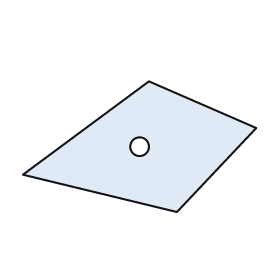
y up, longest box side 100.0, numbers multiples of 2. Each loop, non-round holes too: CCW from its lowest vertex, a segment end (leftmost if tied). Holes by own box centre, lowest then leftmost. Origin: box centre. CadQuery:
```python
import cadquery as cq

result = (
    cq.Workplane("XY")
    .moveTo(16.0, -28.0)
    .lineTo(50.0, 8.0)
    .lineTo(4.0, 28.0)
    .lineTo(-50.0, -12.0)
    .close()
    .moveTo(0.0, 0.0)
    .circle(4.0)
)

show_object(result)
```